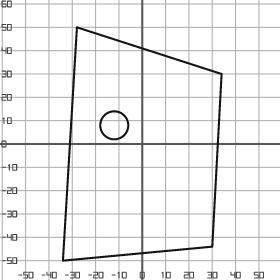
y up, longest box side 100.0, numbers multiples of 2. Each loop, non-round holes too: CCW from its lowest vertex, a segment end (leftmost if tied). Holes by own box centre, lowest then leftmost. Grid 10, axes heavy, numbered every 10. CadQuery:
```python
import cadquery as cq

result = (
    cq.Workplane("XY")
    .moveTo(-34.0, -50.0)
    .lineTo(30.0, -44.0)
    .lineTo(34.0, 30.0)
    .lineTo(-28.0, 50.0)
    .close()
    .moveTo(-12.0, 8.0)
    .circle(6.0)
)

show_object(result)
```